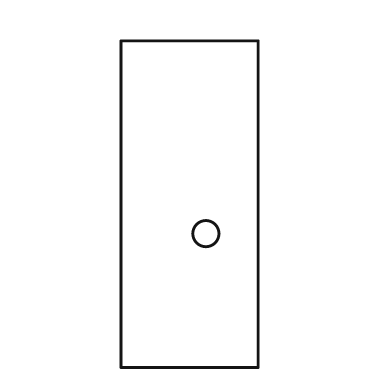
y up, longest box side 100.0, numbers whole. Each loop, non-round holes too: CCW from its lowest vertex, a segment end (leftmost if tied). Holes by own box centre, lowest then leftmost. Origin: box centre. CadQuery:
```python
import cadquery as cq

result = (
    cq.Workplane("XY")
    .moveTo(-21.0, -50.0)
    .lineTo(21.0, -50.0)
    .lineTo(21.0, 50.0)
    .lineTo(-21.0, 50.0)
    .close()
    .moveTo(5.0, -9.0)
    .circle(4.0)
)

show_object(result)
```